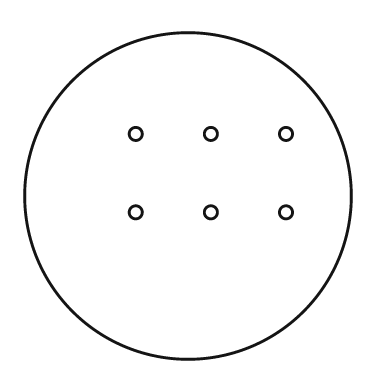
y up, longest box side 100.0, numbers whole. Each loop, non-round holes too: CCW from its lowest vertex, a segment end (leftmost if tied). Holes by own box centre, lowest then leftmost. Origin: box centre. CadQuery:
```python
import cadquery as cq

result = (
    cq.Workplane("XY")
    .moveTo(0.0, 0.0)
    .circle(50.0)
    .moveTo(-16.0, -5.0)
    .circle(2.0)
    .moveTo(7.0, -5.0)
    .circle(2.0)
    .moveTo(30.0, -5.0)
    .circle(2.0)
    .moveTo(-16.0, 19.0)
    .circle(2.0)
    .moveTo(7.0, 19.0)
    .circle(2.0)
    .moveTo(30.0, 19.0)
    .circle(2.0)
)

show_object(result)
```